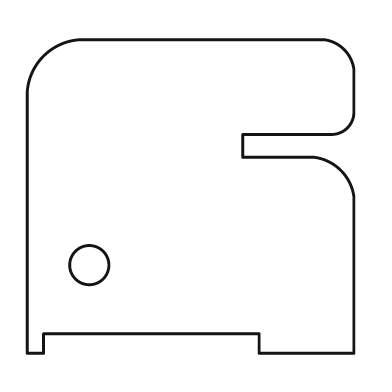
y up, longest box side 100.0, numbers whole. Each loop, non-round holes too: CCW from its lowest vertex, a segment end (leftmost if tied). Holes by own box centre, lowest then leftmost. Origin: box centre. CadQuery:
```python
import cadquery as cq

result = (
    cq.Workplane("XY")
    .moveTo(-50.0, -48.0)
    .lineTo(-45.0, -48.0)
    .lineTo(-45.0, -42.0)
    .lineTo(21.0, -42.0)
    .lineTo(21.0, -48.0)
    .lineTo(50.0, -48.0)
    .lineTo(50.0, 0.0)
    .threePointArc((46.0, 8.0), (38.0, 12.0))
    .lineTo(16.0, 12.0)
    .lineTo(16.0, 19.0)
    .lineTo(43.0, 19.0)
    .threePointArc((48.0, 21.0), (50.0, 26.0))
    .lineTo(50.0, 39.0)
    .threePointArc((47.0, 45.0), (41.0, 48.0))
    .lineTo(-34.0, 48.0)
    .threePointArc((-45.0, 43.0), (-50.0, 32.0))
    .close()
    .moveTo(-31.0, -21.0)
    .circle(6.0)
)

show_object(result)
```